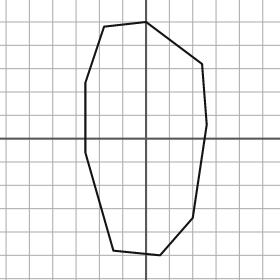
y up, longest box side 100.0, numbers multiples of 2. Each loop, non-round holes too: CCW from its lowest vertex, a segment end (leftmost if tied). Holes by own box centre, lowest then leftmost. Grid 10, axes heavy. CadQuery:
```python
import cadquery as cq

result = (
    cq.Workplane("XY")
    .moveTo(6.0, -50.0)
    .lineTo(20.0, -34.0)
    .lineTo(26.0, 6.0)
    .lineTo(24.0, 32.0)
    .lineTo(0.0, 50.0)
    .lineTo(-18.0, 48.0)
    .lineTo(-26.0, 24.0)
    .lineTo(-26.0, -6.0)
    .lineTo(-14.0, -48.0)
    .close()
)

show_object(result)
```